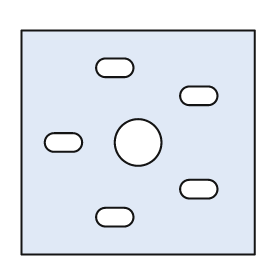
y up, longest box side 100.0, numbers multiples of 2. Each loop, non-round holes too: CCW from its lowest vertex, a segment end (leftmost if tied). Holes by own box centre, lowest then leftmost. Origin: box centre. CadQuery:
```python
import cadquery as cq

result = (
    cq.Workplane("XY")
    .moveTo(-50.0, -48.0)
    .lineTo(50.0, -48.0)
    .lineTo(50.0, 48.0)
    .lineTo(-50.0, 48.0)
    .close()
    .moveTo(-14.0, -36.0)
    .lineTo(-6.0, -36.0)
    .threePointArc((-2.0, -32.0), (-6.0, -28.0))
    .lineTo(-14.0, -28.0)
    .threePointArc((-18.0, -32.0), (-14.0, -36.0))
    .close()
    .moveTo(22.0, -24.0)
    .lineTo(30.0, -24.0)
    .threePointArc((34.0, -20.0), (30.0, -16.0))
    .lineTo(22.0, -16.0)
    .threePointArc((18.0, -20.0), (22.0, -24.0))
    .close()
    .moveTo(-36.0, -4.0)
    .lineTo(-28.0, -4.0)
    .threePointArc((-24.0, 0.0), (-28.0, 4.0))
    .lineTo(-36.0, 4.0)
    .threePointArc((-40.0, 0.0), (-36.0, -4.0))
    .close()
    .moveTo(0.0, 0.0)
    .circle(10.0)
    .moveTo(22.0, 16.0)
    .lineTo(30.0, 16.0)
    .threePointArc((34.0, 20.0), (30.0, 24.0))
    .lineTo(22.0, 24.0)
    .threePointArc((18.0, 20.0), (22.0, 16.0))
    .close()
    .moveTo(-14.0, 28.0)
    .lineTo(-6.0, 28.0)
    .threePointArc((-2.0, 32.0), (-6.0, 36.0))
    .lineTo(-14.0, 36.0)
    .threePointArc((-18.0, 32.0), (-14.0, 28.0))
    .close()
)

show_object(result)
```